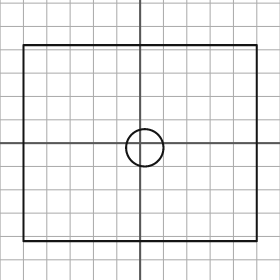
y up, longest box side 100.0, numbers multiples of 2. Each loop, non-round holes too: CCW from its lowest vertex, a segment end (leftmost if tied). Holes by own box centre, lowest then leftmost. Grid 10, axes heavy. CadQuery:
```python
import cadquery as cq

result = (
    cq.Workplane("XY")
    .moveTo(-50.0, -42.0)
    .lineTo(50.0, -42.0)
    .lineTo(50.0, 42.0)
    .lineTo(-50.0, 42.0)
    .close()
    .moveTo(2.0, -2.0)
    .circle(8.0)
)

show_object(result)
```